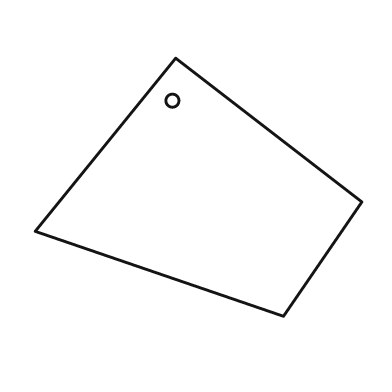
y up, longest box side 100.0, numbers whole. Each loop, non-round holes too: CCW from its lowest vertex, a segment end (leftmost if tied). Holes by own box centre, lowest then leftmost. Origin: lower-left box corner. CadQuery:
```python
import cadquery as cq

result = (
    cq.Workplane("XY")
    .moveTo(76.0, 0.0)
    .lineTo(100.0, 35.0)
    .lineTo(43.0, 79.0)
    .lineTo(0.0, 26.0)
    .close()
    .moveTo(42.0, 66.0)
    .circle(2.0)
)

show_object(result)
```